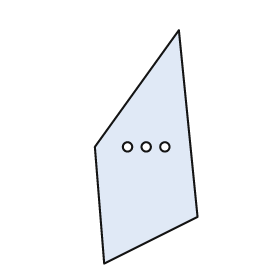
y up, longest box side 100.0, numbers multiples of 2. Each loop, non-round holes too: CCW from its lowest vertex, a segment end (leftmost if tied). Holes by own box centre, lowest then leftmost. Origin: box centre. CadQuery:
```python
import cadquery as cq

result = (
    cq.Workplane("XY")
    .moveTo(-18.0, -50.0)
    .lineTo(22.0, -30.0)
    .lineTo(14.0, 50.0)
    .lineTo(-22.0, 0.0)
    .close()
    .moveTo(-8.0, 0.0)
    .circle(2.0)
    .moveTo(0.0, 0.0)
    .circle(2.0)
    .moveTo(8.0, 0.0)
    .circle(2.0)
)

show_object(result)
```